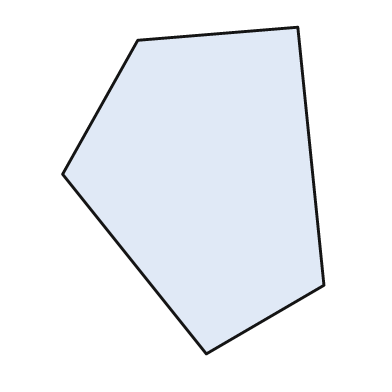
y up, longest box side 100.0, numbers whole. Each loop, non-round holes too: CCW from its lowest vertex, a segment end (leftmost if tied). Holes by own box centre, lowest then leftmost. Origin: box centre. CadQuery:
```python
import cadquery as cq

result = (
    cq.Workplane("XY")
    .moveTo(4.0, -50.0)
    .lineTo(40.0, -29.0)
    .lineTo(32.0, 50.0)
    .lineTo(-17.0, 46.0)
    .lineTo(-40.0, 5.0)
    .close()
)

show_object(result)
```